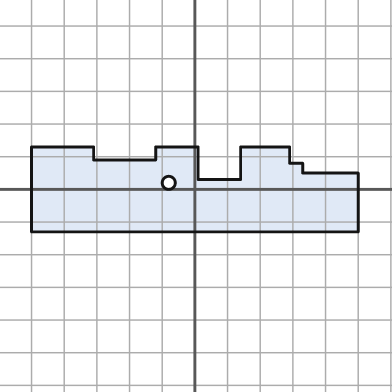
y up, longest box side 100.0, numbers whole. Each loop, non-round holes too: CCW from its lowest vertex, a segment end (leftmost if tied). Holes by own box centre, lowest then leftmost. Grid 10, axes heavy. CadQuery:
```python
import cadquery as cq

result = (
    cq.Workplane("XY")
    .moveTo(-50.0, -13.0)
    .lineTo(50.0, -13.0)
    .lineTo(50.0, 5.0)
    .lineTo(33.0, 5.0)
    .lineTo(33.0, 8.0)
    .lineTo(29.0, 8.0)
    .lineTo(29.0, 13.0)
    .lineTo(14.0, 13.0)
    .lineTo(14.0, 3.0)
    .lineTo(1.0, 3.0)
    .lineTo(1.0, 13.0)
    .lineTo(-12.0, 13.0)
    .lineTo(-12.0, 9.0)
    .lineTo(-31.0, 9.0)
    .lineTo(-31.0, 13.0)
    .lineTo(-50.0, 13.0)
    .close()
    .moveTo(-8.0, 2.0)
    .circle(2.0)
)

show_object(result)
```